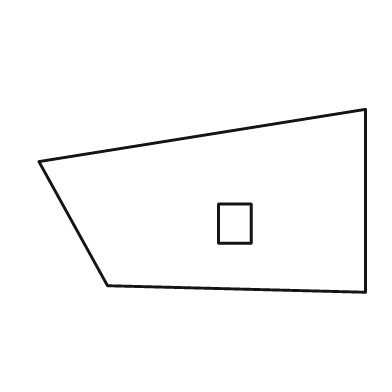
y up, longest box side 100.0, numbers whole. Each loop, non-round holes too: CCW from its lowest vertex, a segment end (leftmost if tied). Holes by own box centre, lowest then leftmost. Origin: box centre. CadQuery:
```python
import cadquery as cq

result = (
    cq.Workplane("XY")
    .moveTo(50.0, -28.0)
    .lineTo(50.0, 28.0)
    .lineTo(-50.0, 12.0)
    .lineTo(-29.0, -26.0)
    .close()
    .moveTo(5.0, -13.0)
    .lineTo(15.0, -13.0)
    .lineTo(15.0, -1.0)
    .lineTo(5.0, -1.0)
    .close()
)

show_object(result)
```